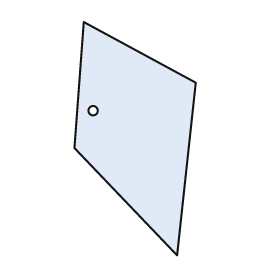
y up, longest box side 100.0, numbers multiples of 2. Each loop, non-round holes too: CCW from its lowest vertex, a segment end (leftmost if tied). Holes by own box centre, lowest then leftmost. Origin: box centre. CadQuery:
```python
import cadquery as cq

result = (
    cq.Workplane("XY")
    .moveTo(18.0, -50.0)
    .lineTo(26.0, 24.0)
    .lineTo(-22.0, 50.0)
    .lineTo(-26.0, -4.0)
    .close()
    .moveTo(-18.0, 12.0)
    .circle(2.0)
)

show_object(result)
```